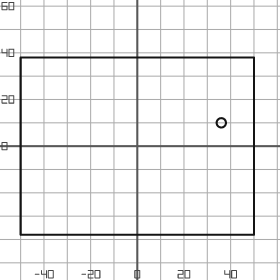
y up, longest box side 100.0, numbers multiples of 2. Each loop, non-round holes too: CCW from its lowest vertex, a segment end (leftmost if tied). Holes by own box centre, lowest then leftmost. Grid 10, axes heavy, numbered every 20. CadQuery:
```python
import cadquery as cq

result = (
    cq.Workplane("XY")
    .moveTo(-50.0, -38.0)
    .lineTo(50.0, -38.0)
    .lineTo(50.0, 38.0)
    .lineTo(-50.0, 38.0)
    .close()
    .moveTo(36.0, 10.0)
    .circle(2.0)
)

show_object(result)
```